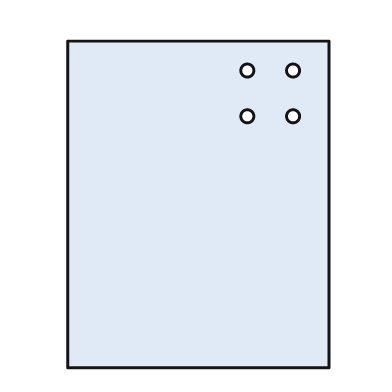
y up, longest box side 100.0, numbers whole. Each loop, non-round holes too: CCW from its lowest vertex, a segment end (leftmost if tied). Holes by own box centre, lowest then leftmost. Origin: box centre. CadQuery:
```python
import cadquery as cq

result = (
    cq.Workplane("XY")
    .moveTo(-40.0, -50.0)
    .lineTo(40.0, -50.0)
    .lineTo(40.0, 50.0)
    .lineTo(-40.0, 50.0)
    .close()
    .moveTo(15.0, 27.0)
    .circle(2.0)
    .moveTo(29.0, 27.0)
    .circle(2.0)
    .moveTo(15.0, 41.0)
    .circle(2.0)
    .moveTo(29.0, 41.0)
    .circle(2.0)
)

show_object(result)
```